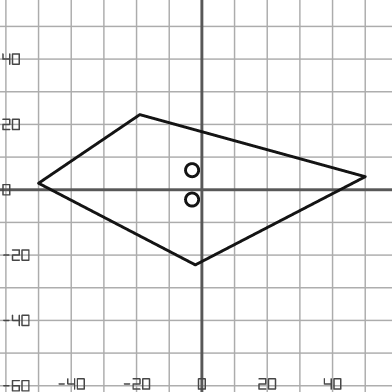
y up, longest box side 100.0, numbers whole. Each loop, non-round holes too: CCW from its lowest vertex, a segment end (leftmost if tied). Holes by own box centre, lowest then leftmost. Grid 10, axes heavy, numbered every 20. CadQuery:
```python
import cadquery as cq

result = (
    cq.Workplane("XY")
    .moveTo(-2.0, -23.0)
    .lineTo(50.0, 4.0)
    .lineTo(-19.0, 23.0)
    .lineTo(-50.0, 2.0)
    .close()
    .moveTo(-3.0, -3.0)
    .circle(2.0)
    .moveTo(-3.0, 6.0)
    .circle(2.0)
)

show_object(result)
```